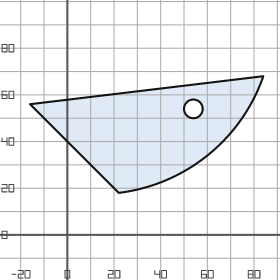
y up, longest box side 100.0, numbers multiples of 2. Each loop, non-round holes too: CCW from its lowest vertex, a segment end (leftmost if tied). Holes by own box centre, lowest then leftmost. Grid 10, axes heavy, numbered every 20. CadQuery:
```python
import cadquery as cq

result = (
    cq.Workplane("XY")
    .moveTo(22.0, 18.0)
    .threePointArc((60.0, 34.0), (84.0, 68.0))
    .lineTo(-16.0, 56.0)
    .close()
    .moveTo(54.0, 54.0)
    .circle(4.0)
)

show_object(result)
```